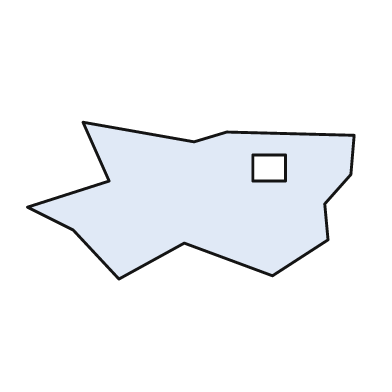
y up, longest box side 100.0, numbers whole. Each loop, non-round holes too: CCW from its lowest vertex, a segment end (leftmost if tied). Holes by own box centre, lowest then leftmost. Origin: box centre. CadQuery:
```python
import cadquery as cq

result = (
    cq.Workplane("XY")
    .moveTo(-22.0, -24.0)
    .lineTo(-2.0, -13.0)
    .lineTo(25.0, -23.0)
    .lineTo(42.0, -12.0)
    .lineTo(41.0, -1.0)
    .lineTo(49.0, 8.0)
    .lineTo(50.0, 20.0)
    .lineTo(11.0, 21.0)
    .lineTo(1.0, 18.0)
    .lineTo(-33.0, 24.0)
    .lineTo(-25.0, 6.0)
    .lineTo(-50.0, -2.0)
    .lineTo(-36.0, -9.0)
    .close()
    .moveTo(19.0, 6.0)
    .lineTo(29.0, 6.0)
    .lineTo(29.0, 14.0)
    .lineTo(19.0, 14.0)
    .close()
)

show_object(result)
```